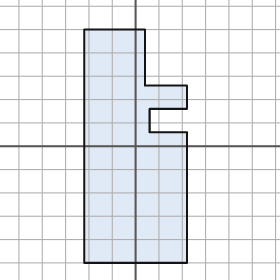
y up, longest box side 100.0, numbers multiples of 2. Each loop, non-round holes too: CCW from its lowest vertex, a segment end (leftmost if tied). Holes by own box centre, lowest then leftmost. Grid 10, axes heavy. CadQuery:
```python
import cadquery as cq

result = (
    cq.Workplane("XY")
    .moveTo(-22.0, -50.0)
    .lineTo(22.0, -50.0)
    .lineTo(22.0, 6.0)
    .lineTo(6.0, 6.0)
    .lineTo(6.0, 16.0)
    .lineTo(22.0, 16.0)
    .lineTo(22.0, 26.0)
    .lineTo(4.0, 26.0)
    .lineTo(4.0, 50.0)
    .lineTo(-22.0, 50.0)
    .close()
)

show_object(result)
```